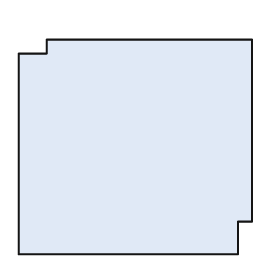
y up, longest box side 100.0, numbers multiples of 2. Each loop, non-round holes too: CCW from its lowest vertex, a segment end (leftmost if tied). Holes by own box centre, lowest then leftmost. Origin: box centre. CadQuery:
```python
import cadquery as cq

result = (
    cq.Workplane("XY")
    .moveTo(-50.0, -46.0)
    .lineTo(44.0, -46.0)
    .lineTo(44.0, -32.0)
    .lineTo(50.0, -32.0)
    .lineTo(50.0, 46.0)
    .lineTo(-38.0, 46.0)
    .lineTo(-38.0, 40.0)
    .lineTo(-50.0, 40.0)
    .close()
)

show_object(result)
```